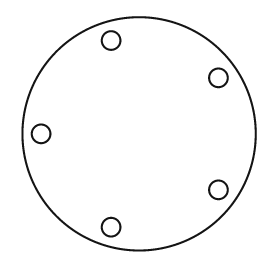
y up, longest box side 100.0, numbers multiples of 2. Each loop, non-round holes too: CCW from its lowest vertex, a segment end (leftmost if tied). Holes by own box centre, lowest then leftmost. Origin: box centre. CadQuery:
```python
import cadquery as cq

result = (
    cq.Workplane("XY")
    .moveTo(0.0, 0.0)
    .circle(50.0)
    .moveTo(-12.0, -40.0)
    .circle(4.0)
    .moveTo(34.0, -24.0)
    .circle(4.0)
    .moveTo(-42.0, 0.0)
    .circle(4.0)
    .moveTo(34.0, 24.0)
    .circle(4.0)
    .moveTo(-12.0, 40.0)
    .circle(4.0)
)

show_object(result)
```